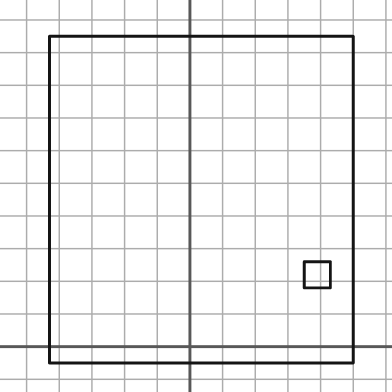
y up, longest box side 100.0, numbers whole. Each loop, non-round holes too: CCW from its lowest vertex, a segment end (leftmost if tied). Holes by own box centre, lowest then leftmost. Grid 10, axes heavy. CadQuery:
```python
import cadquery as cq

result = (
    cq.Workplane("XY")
    .moveTo(-43.0, -5.0)
    .lineTo(50.0, -5.0)
    .lineTo(50.0, 95.0)
    .lineTo(-43.0, 95.0)
    .close()
    .moveTo(35.0, 18.0)
    .lineTo(43.0, 18.0)
    .lineTo(43.0, 26.0)
    .lineTo(35.0, 26.0)
    .close()
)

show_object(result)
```